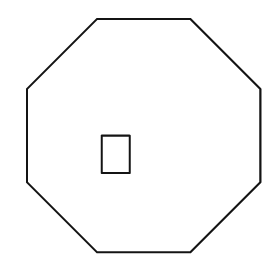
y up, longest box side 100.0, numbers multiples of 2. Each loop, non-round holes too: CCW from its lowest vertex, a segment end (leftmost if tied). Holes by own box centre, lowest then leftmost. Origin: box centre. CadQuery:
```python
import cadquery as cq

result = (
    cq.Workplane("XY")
    .moveTo(-20.0, -50.0)
    .lineTo(20.0, -50.0)
    .lineTo(50.0, -20.0)
    .lineTo(50.0, 20.0)
    .lineTo(20.0, 50.0)
    .lineTo(-20.0, 50.0)
    .lineTo(-50.0, 20.0)
    .lineTo(-50.0, -20.0)
    .close()
    .moveTo(-18.0, -16.0)
    .lineTo(-6.0, -16.0)
    .lineTo(-6.0, 0.0)
    .lineTo(-18.0, 0.0)
    .close()
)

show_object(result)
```